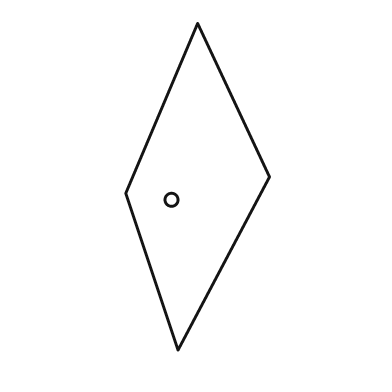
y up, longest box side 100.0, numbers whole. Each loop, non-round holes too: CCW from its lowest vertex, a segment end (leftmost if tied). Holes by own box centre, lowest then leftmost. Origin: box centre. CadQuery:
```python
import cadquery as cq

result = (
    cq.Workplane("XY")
    .moveTo(-6.0, -50.0)
    .lineTo(22.0, 3.0)
    .lineTo(0.0, 50.0)
    .lineTo(-22.0, -2.0)
    .close()
    .moveTo(-8.0, -4.0)
    .circle(2.0)
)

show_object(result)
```